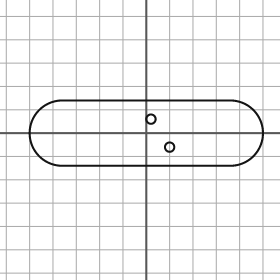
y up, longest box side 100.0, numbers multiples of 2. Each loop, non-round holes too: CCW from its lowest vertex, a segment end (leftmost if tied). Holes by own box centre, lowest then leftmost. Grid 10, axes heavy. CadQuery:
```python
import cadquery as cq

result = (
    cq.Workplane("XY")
    .moveTo(-36.0, -14.0)
    .lineTo(36.0, -14.0)
    .threePointArc((50.0, 0.0), (36.0, 14.0))
    .lineTo(-36.0, 14.0)
    .threePointArc((-50.0, 0.0), (-36.0, -14.0))
    .close()
    .moveTo(10.0, -6.0)
    .circle(2.0)
    .moveTo(2.0, 6.0)
    .circle(2.0)
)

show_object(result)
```